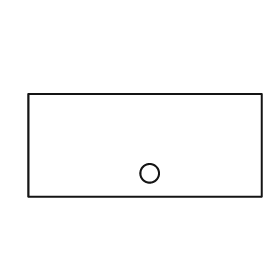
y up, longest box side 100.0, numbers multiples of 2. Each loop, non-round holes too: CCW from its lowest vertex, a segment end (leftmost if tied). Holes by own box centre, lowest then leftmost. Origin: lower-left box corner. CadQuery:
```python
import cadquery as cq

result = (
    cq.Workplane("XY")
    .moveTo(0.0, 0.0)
    .lineTo(100.0, 0.0)
    .lineTo(100.0, 44.0)
    .lineTo(0.0, 44.0)
    .close()
    .moveTo(52.0, 10.0)
    .circle(4.0)
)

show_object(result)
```